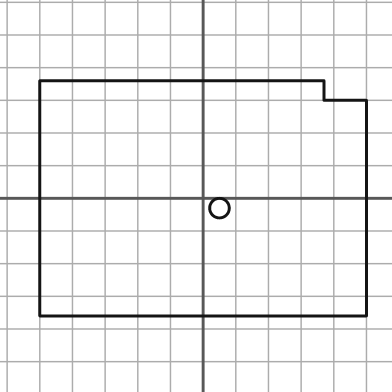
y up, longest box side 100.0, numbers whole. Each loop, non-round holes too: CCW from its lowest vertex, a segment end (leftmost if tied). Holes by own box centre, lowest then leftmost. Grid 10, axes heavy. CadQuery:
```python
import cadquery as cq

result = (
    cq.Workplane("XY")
    .moveTo(-50.0, -36.0)
    .lineTo(50.0, -36.0)
    .lineTo(50.0, 30.0)
    .lineTo(37.0, 30.0)
    .lineTo(37.0, 36.0)
    .lineTo(-50.0, 36.0)
    .close()
    .moveTo(5.0, -3.0)
    .circle(3.0)
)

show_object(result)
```